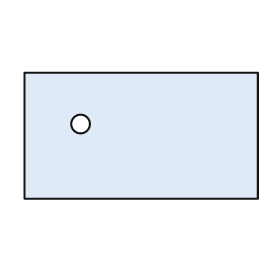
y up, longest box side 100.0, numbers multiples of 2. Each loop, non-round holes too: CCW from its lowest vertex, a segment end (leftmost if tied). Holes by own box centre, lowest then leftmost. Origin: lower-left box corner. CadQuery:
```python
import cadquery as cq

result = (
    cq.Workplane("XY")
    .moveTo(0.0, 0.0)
    .lineTo(100.0, 0.0)
    .lineTo(100.0, 54.0)
    .lineTo(0.0, 54.0)
    .close()
    .moveTo(24.0, 32.0)
    .circle(4.0)
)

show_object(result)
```